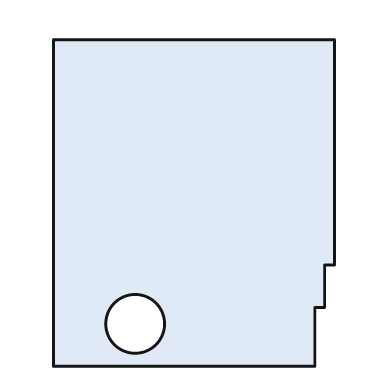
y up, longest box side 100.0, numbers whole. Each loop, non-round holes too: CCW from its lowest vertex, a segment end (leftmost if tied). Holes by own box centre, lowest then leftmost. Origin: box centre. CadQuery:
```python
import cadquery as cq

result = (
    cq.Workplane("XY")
    .moveTo(-43.0, -50.0)
    .lineTo(37.0, -50.0)
    .lineTo(37.0, -32.0)
    .lineTo(40.0, -32.0)
    .lineTo(40.0, -19.0)
    .lineTo(43.0, -19.0)
    .lineTo(43.0, 50.0)
    .lineTo(-43.0, 50.0)
    .close()
    .moveTo(-18.0, -37.0)
    .circle(9.0)
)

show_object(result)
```